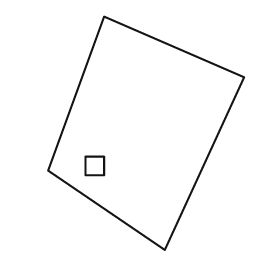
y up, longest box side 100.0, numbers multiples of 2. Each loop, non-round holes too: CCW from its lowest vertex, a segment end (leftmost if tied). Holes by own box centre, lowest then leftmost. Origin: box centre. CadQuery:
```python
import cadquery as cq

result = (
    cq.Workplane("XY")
    .moveTo(8.0, -50.0)
    .lineTo(42.0, 24.0)
    .lineTo(-18.0, 50.0)
    .lineTo(-42.0, -16.0)
    .close()
    .moveTo(-26.0, -18.0)
    .lineTo(-18.0, -18.0)
    .lineTo(-18.0, -10.0)
    .lineTo(-26.0, -10.0)
    .close()
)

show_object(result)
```